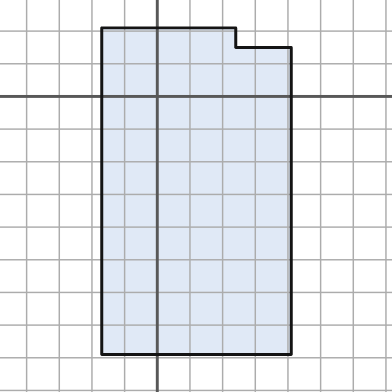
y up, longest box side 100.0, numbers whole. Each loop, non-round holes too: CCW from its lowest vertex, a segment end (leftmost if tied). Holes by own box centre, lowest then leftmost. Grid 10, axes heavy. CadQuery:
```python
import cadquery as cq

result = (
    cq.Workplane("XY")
    .moveTo(-17.0, -79.0)
    .lineTo(41.0, -79.0)
    .lineTo(41.0, 15.0)
    .lineTo(24.0, 15.0)
    .lineTo(24.0, 21.0)
    .lineTo(-17.0, 21.0)
    .close()
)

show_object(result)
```